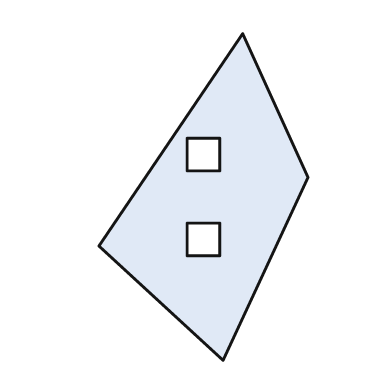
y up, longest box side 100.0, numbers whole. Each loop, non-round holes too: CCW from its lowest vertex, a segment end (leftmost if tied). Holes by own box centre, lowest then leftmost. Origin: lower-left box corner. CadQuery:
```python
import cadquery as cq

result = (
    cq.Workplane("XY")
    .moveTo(38.0, 0.0)
    .lineTo(64.0, 56.0)
    .lineTo(44.0, 100.0)
    .lineTo(0.0, 35.0)
    .close()
    .moveTo(27.0, 32.0)
    .lineTo(37.0, 32.0)
    .lineTo(37.0, 42.0)
    .lineTo(27.0, 42.0)
    .close()
    .moveTo(27.0, 58.0)
    .lineTo(37.0, 58.0)
    .lineTo(37.0, 68.0)
    .lineTo(27.0, 68.0)
    .close()
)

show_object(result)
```